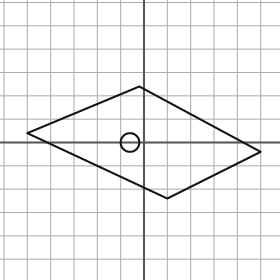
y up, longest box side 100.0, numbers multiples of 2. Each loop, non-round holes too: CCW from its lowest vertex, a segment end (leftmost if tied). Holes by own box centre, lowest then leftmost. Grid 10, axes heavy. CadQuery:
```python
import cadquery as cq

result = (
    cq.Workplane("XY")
    .moveTo(10.0, -24.0)
    .lineTo(50.0, -4.0)
    .lineTo(-2.0, 24.0)
    .lineTo(-50.0, 4.0)
    .close()
    .moveTo(-6.0, 0.0)
    .circle(4.0)
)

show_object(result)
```